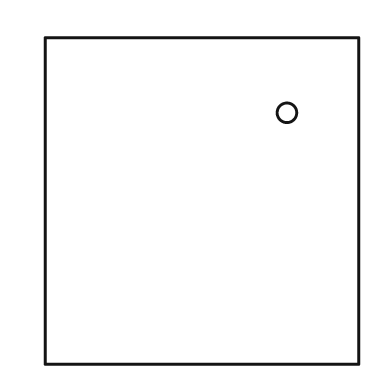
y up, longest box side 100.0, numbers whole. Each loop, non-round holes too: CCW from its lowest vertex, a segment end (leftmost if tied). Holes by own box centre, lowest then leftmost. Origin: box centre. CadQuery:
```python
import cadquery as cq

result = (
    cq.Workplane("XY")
    .moveTo(-48.0, -50.0)
    .lineTo(48.0, -50.0)
    .lineTo(48.0, 50.0)
    .lineTo(-48.0, 50.0)
    .close()
    .moveTo(26.0, 27.0)
    .circle(3.0)
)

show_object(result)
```